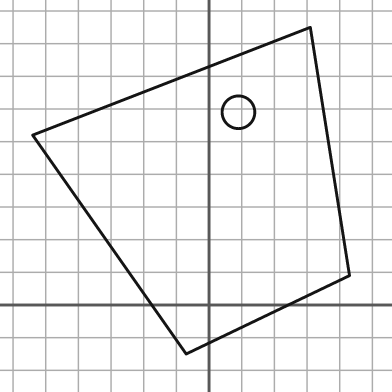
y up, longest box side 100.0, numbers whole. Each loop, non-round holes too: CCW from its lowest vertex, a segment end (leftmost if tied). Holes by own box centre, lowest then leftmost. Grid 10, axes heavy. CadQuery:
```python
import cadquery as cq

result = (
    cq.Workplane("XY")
    .moveTo(-7.0, -15.0)
    .lineTo(43.0, 9.0)
    .lineTo(31.0, 85.0)
    .lineTo(-54.0, 52.0)
    .close()
    .moveTo(9.0, 59.0)
    .circle(5.0)
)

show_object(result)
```